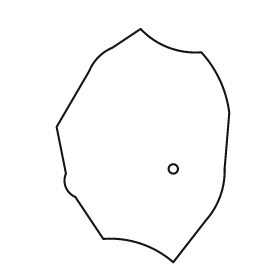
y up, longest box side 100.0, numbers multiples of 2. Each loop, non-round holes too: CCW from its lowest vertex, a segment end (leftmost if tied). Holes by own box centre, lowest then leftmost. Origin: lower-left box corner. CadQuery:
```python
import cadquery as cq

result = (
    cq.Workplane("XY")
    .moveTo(50.0, 0.0)
    .lineTo(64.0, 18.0)
    .threePointArc((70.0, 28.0), (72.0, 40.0))
    .lineTo(74.0, 64.0)
    .threePointArc((70.0, 78.0), (62.0, 90.0))
    .threePointArc((48.0, 92.0), (36.0, 100.0))
    .lineTo(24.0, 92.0)
    .threePointArc((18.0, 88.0), (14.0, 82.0))
    .lineTo(0.0, 58.0)
    .lineTo(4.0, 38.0)
    .threePointArc((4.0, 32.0), (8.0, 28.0))
    .lineTo(20.0, 10.0)
    .threePointArc((36.0, 8.0), (50.0, 0.0))
    .close()
    .moveTo(50.0, 40.0)
    .circle(2.0)
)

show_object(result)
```